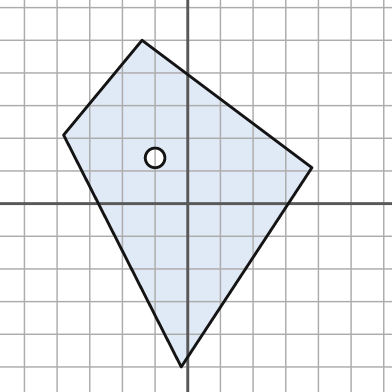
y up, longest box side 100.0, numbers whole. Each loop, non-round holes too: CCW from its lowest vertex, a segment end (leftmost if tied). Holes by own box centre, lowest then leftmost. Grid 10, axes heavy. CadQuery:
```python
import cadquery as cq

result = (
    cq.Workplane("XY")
    .moveTo(-2.0, -50.0)
    .lineTo(38.0, 11.0)
    .lineTo(-14.0, 50.0)
    .lineTo(-38.0, 21.0)
    .close()
    .moveTo(-10.0, 14.0)
    .circle(3.0)
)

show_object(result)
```